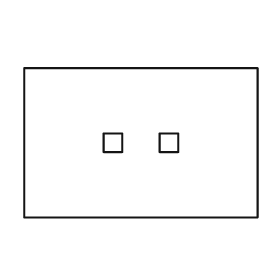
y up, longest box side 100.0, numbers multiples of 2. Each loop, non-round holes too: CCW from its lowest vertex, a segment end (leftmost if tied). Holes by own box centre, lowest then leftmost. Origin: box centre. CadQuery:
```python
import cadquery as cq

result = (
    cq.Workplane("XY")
    .moveTo(-50.0, -32.0)
    .lineTo(50.0, -32.0)
    .lineTo(50.0, 32.0)
    .lineTo(-50.0, 32.0)
    .close()
    .moveTo(-16.0, -4.0)
    .lineTo(-8.0, -4.0)
    .lineTo(-8.0, 4.0)
    .lineTo(-16.0, 4.0)
    .close()
    .moveTo(8.0, -4.0)
    .lineTo(16.0, -4.0)
    .lineTo(16.0, 4.0)
    .lineTo(8.0, 4.0)
    .close()
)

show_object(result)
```